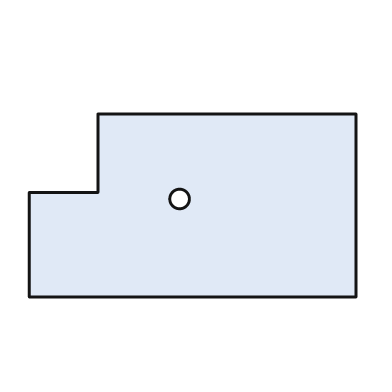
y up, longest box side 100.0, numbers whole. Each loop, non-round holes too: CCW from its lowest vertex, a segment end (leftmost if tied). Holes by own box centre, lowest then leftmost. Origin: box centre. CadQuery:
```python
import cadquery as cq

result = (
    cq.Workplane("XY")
    .moveTo(-50.0, -28.0)
    .lineTo(50.0, -28.0)
    .lineTo(50.0, 28.0)
    .lineTo(-29.0, 28.0)
    .lineTo(-29.0, 4.0)
    .lineTo(-50.0, 4.0)
    .close()
    .moveTo(-4.0, 2.0)
    .circle(3.0)
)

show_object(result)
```